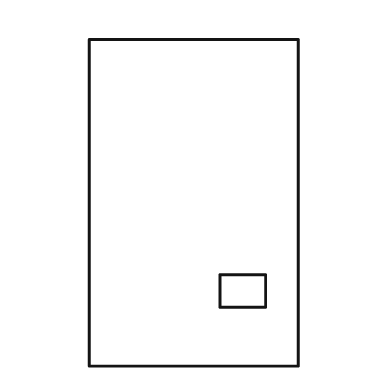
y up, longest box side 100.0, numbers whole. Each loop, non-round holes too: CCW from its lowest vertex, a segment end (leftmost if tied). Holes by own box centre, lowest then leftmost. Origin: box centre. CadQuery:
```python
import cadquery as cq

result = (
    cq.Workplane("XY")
    .moveTo(-32.0, -50.0)
    .lineTo(32.0, -50.0)
    .lineTo(32.0, 50.0)
    .lineTo(-32.0, 50.0)
    .close()
    .moveTo(8.0, -32.0)
    .lineTo(22.0, -32.0)
    .lineTo(22.0, -22.0)
    .lineTo(8.0, -22.0)
    .close()
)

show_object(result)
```